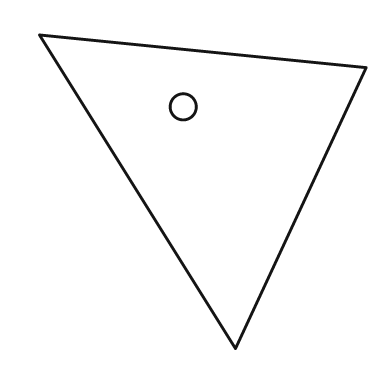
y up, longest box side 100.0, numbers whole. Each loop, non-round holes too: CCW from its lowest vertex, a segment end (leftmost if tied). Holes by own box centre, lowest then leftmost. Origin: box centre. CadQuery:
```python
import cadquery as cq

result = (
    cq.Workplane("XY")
    .moveTo(10.0, -48.0)
    .lineTo(50.0, 38.0)
    .lineTo(-50.0, 48.0)
    .close()
    .moveTo(-6.0, 26.0)
    .circle(4.0)
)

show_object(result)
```